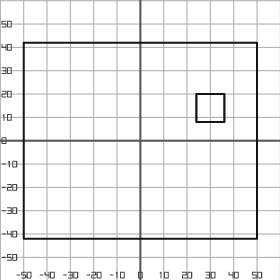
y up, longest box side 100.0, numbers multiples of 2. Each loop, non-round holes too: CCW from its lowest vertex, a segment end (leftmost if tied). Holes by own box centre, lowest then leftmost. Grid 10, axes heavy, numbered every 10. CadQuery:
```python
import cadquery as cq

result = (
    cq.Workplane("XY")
    .moveTo(-50.0, -42.0)
    .lineTo(50.0, -42.0)
    .lineTo(50.0, 42.0)
    .lineTo(-50.0, 42.0)
    .close()
    .moveTo(24.0, 8.0)
    .lineTo(36.0, 8.0)
    .lineTo(36.0, 20.0)
    .lineTo(24.0, 20.0)
    .close()
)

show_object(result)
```